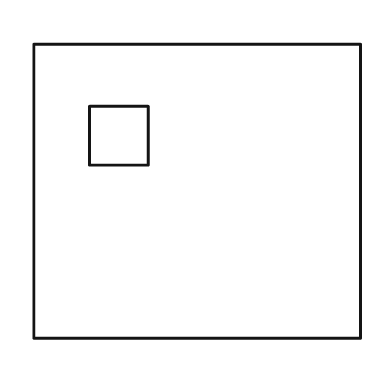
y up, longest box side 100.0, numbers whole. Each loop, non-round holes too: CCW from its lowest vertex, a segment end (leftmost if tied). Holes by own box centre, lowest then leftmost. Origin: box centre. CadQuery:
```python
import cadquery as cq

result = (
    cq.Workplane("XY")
    .moveTo(-50.0, -45.0)
    .lineTo(50.0, -45.0)
    .lineTo(50.0, 45.0)
    .lineTo(-50.0, 45.0)
    .close()
    .moveTo(-33.0, 8.0)
    .lineTo(-15.0, 8.0)
    .lineTo(-15.0, 26.0)
    .lineTo(-33.0, 26.0)
    .close()
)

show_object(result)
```